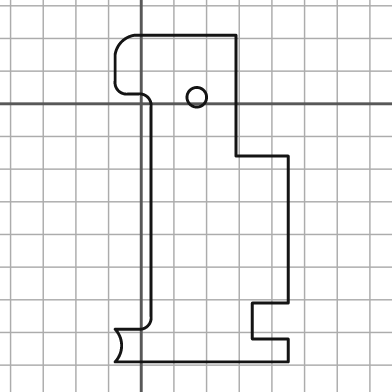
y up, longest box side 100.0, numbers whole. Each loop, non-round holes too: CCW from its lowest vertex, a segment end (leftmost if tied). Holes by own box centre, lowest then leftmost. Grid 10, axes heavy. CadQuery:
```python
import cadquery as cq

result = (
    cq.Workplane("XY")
    .moveTo(-8.0, -79.0)
    .lineTo(45.0, -79.0)
    .lineTo(45.0, -72.0)
    .lineTo(34.0, -72.0)
    .lineTo(34.0, -61.0)
    .lineTo(45.0, -61.0)
    .lineTo(45.0, -16.0)
    .lineTo(29.0, -16.0)
    .lineTo(29.0, 21.0)
    .lineTo(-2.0, 21.0)
    .threePointArc((-6.0, 19.0), (-8.0, 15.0))
    .lineTo(-8.0, 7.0)
    .threePointArc((-7.0, 4.0), (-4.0, 3.0))
    .lineTo(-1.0, 3.0)
    .threePointArc((2.0, 2.0), (3.0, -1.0))
    .lineTo(3.0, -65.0)
    .threePointArc((2.0, -68.0), (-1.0, -69.0))
    .lineTo(-8.0, -69.0)
    .threePointArc((-6.0, -74.0), (-8.0, -79.0))
    .close()
    .moveTo(17.0, 2.0)
    .circle(3.0)
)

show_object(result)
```